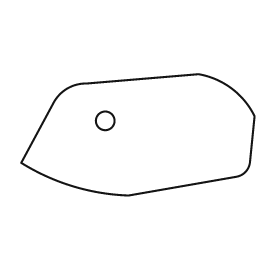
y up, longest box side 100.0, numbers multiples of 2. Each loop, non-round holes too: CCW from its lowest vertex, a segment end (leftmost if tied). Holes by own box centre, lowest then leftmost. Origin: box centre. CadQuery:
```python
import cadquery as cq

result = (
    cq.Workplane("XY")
    .moveTo(-4.0, -26.0)
    .lineTo(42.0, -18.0)
    .threePointArc((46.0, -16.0), (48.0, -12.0))
    .lineTo(50.0, 8.0)
    .threePointArc((40.0, 20.0), (26.0, 26.0))
    .lineTo(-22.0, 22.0)
    .threePointArc((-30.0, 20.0), (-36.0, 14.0))
    .lineTo(-50.0, -12.0)
    .threePointArc((-28.0, -22.0), (-4.0, -26.0))
    .close()
    .moveTo(-14.0, 6.0)
    .circle(4.0)
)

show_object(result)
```